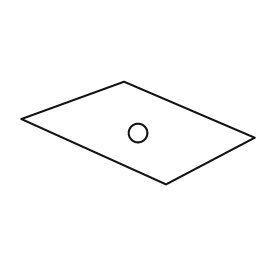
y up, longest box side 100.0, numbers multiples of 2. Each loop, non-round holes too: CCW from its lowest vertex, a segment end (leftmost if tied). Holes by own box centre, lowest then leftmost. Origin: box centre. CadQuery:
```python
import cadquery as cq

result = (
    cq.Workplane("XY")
    .moveTo(12.0, -22.0)
    .lineTo(50.0, -2.0)
    .lineTo(-6.0, 22.0)
    .lineTo(-50.0, 6.0)
    .close()
    .moveTo(0.0, 0.0)
    .circle(4.0)
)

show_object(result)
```